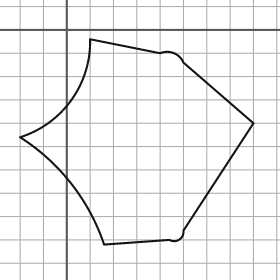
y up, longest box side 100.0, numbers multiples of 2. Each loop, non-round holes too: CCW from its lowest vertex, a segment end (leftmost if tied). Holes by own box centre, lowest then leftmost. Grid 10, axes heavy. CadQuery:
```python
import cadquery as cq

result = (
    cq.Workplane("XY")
    .moveTo(16.0, -92.0)
    .lineTo(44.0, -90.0)
    .threePointArc((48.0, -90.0), (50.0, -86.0))
    .lineTo(80.0, -40.0)
    .lineTo(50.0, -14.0)
    .threePointArc((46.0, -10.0), (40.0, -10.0))
    .lineTo(10.0, -4.0)
    .threePointArc((2.0, -30.0), (-20.0, -46.0))
    .threePointArc((2.0, -66.0), (16.0, -92.0))
    .close()
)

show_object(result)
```